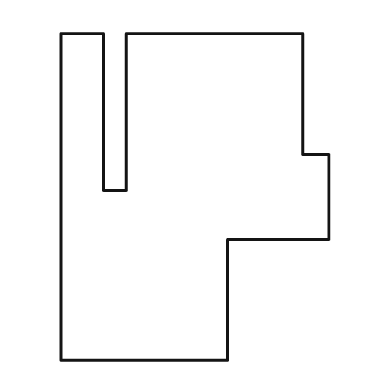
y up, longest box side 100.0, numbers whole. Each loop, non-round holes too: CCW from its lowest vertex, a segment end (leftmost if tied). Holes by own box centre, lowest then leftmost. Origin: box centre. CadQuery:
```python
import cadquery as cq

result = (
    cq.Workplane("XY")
    .moveTo(-41.0, -50.0)
    .lineTo(10.0, -50.0)
    .lineTo(10.0, -13.0)
    .lineTo(41.0, -13.0)
    .lineTo(41.0, 13.0)
    .lineTo(33.0, 13.0)
    .lineTo(33.0, 50.0)
    .lineTo(-21.0, 50.0)
    .lineTo(-21.0, 2.0)
    .lineTo(-28.0, 2.0)
    .lineTo(-28.0, 50.0)
    .lineTo(-41.0, 50.0)
    .close()
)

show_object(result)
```